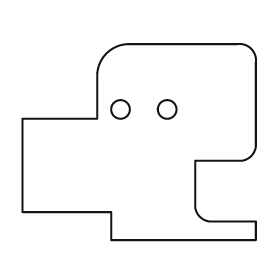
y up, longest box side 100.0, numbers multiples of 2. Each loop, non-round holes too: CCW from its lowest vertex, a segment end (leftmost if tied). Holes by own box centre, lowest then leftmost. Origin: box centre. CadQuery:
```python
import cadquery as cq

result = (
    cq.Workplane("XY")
    .moveTo(-12.0, -42.0)
    .lineTo(50.0, -42.0)
    .lineTo(50.0, -34.0)
    .lineTo(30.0, -34.0)
    .threePointArc((26.0, -32.0), (24.0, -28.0))
    .lineTo(24.0, -8.0)
    .lineTo(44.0, -8.0)
    .threePointArc((48.0, -6.0), (50.0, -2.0))
    .lineTo(50.0, 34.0)
    .threePointArc((48.0, 40.0), (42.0, 42.0))
    .lineTo(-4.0, 42.0)
    .threePointArc((-14.0, 38.0), (-18.0, 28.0))
    .lineTo(-18.0, 10.0)
    .lineTo(-50.0, 10.0)
    .lineTo(-50.0, -30.0)
    .lineTo(-12.0, -30.0)
    .close()
    .moveTo(-8.0, 14.0)
    .circle(4.0)
    .moveTo(12.0, 14.0)
    .circle(4.0)
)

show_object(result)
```